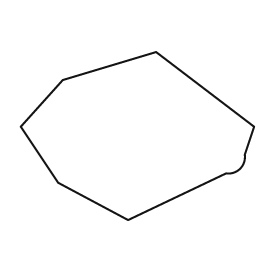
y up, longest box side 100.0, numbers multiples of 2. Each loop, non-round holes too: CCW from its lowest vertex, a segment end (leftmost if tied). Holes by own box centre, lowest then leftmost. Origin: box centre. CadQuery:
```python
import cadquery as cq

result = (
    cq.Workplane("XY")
    .moveTo(-4.0, -36.0)
    .lineTo(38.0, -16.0)
    .threePointArc((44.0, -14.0), (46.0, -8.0))
    .lineTo(50.0, 4.0)
    .lineTo(8.0, 36.0)
    .lineTo(-32.0, 24.0)
    .lineTo(-50.0, 4.0)
    .lineTo(-34.0, -20.0)
    .close()
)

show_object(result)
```